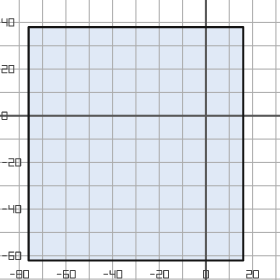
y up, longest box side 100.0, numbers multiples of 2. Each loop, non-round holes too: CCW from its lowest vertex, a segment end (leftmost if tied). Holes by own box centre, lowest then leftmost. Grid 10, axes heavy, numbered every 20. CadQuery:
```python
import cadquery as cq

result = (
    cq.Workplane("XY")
    .moveTo(-76.0, -62.0)
    .lineTo(16.0, -62.0)
    .lineTo(16.0, 38.0)
    .lineTo(-76.0, 38.0)
    .close()
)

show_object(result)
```